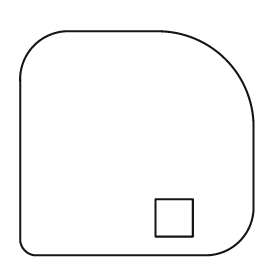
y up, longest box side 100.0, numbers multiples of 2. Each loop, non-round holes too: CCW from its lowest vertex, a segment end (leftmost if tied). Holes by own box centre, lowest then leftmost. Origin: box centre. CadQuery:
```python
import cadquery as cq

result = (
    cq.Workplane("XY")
    .moveTo(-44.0, -48.0)
    .lineTo(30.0, -48.0)
    .threePointArc((44.0, -42.0), (50.0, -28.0))
    .lineTo(50.0, 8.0)
    .threePointArc((38.0, 36.0), (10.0, 48.0))
    .lineTo(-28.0, 48.0)
    .threePointArc((-44.0, 42.0), (-50.0, 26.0))
    .lineTo(-50.0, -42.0)
    .threePointArc((-48.0, -46.0), (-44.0, -48.0))
    .close()
    .moveTo(8.0, -40.0)
    .lineTo(24.0, -40.0)
    .lineTo(24.0, -24.0)
    .lineTo(8.0, -24.0)
    .close()
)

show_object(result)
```